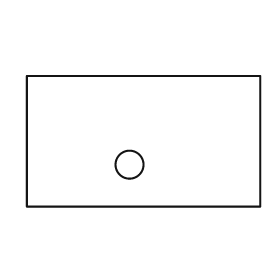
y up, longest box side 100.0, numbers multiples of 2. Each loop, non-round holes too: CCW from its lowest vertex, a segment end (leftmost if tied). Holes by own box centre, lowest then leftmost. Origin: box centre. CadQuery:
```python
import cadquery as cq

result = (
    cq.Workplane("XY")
    .moveTo(-50.0, -28.0)
    .lineTo(50.0, -28.0)
    .lineTo(50.0, 28.0)
    .lineTo(-50.0, 28.0)
    .close()
    .moveTo(-6.0, -10.0)
    .circle(6.0)
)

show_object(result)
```